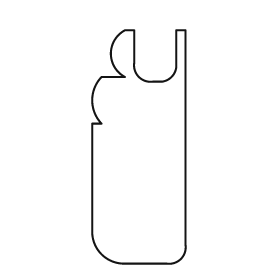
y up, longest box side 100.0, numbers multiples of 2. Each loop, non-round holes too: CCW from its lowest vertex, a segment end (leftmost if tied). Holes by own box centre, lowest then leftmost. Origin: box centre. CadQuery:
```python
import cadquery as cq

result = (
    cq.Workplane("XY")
    .moveTo(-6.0, -50.0)
    .lineTo(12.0, -50.0)
    .threePointArc((18.0, -48.0), (20.0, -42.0))
    .lineTo(20.0, 50.0)
    .lineTo(16.0, 50.0)
    .lineTo(16.0, 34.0)
    .threePointArc((14.0, 30.0), (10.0, 28.0))
    .lineTo(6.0, 28.0)
    .threePointArc((0.0, 30.0), (-2.0, 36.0))
    .lineTo(-2.0, 50.0)
    .lineTo(-6.0, 50.0)
    .threePointArc((-12.0, 40.0), (-6.0, 30.0))
    .lineTo(-16.0, 30.0)
    .threePointArc((-20.0, 20.0), (-16.0, 10.0))
    .lineTo(-20.0, 10.0)
    .lineTo(-20.0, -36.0)
    .threePointArc((-16.0, -46.0), (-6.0, -50.0))
    .close()
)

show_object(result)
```